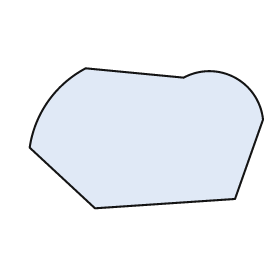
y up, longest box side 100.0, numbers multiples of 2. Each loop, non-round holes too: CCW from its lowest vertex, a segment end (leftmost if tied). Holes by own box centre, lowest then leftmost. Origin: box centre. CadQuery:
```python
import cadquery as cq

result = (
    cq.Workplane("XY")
    .moveTo(-22.0, -30.0)
    .lineTo(38.0, -26.0)
    .lineTo(50.0, 8.0)
    .threePointArc((38.0, 26.0), (16.0, 26.0))
    .lineTo(-26.0, 30.0)
    .threePointArc((-42.0, 16.0), (-50.0, -4.0))
    .close()
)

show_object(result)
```